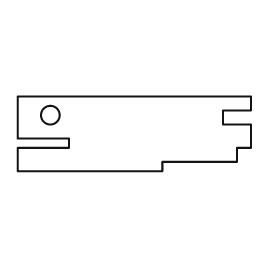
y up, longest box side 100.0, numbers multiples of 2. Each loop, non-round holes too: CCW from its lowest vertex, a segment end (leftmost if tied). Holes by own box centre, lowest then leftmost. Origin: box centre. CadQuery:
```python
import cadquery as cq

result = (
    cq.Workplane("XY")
    .moveTo(-50.0, -16.0)
    .lineTo(12.0, -16.0)
    .lineTo(12.0, -12.0)
    .lineTo(44.0, -12.0)
    .lineTo(44.0, -6.0)
    .lineTo(50.0, -6.0)
    .lineTo(50.0, 4.0)
    .lineTo(38.0, 4.0)
    .lineTo(38.0, 10.0)
    .lineTo(50.0, 10.0)
    .lineTo(50.0, 16.0)
    .lineTo(-50.0, 16.0)
    .lineTo(-50.0, -2.0)
    .lineTo(-28.0, -2.0)
    .lineTo(-28.0, -6.0)
    .lineTo(-50.0, -6.0)
    .close()
    .moveTo(-36.0, 8.0)
    .circle(4.0)
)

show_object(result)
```